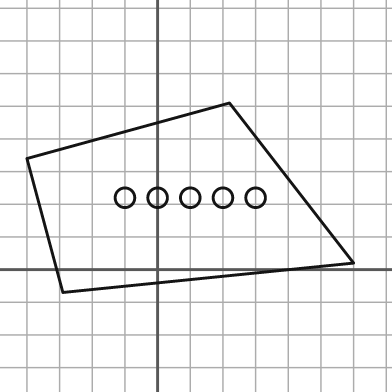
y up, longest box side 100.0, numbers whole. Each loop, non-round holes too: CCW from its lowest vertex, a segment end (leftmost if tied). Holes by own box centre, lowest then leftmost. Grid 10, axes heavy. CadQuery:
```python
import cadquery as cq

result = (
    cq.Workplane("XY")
    .moveTo(-29.0, -7.0)
    .lineTo(60.0, 2.0)
    .lineTo(22.0, 51.0)
    .lineTo(-40.0, 34.0)
    .close()
    .moveTo(-10.0, 22.0)
    .circle(3.0)
    .moveTo(0.0, 22.0)
    .circle(3.0)
    .moveTo(10.0, 22.0)
    .circle(3.0)
    .moveTo(20.0, 22.0)
    .circle(3.0)
    .moveTo(30.0, 22.0)
    .circle(3.0)
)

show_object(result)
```